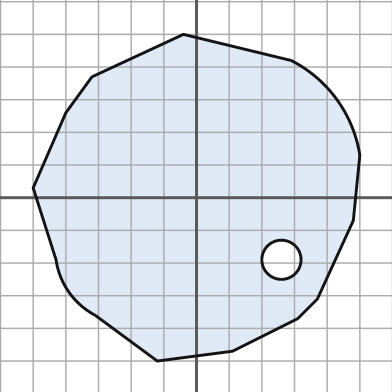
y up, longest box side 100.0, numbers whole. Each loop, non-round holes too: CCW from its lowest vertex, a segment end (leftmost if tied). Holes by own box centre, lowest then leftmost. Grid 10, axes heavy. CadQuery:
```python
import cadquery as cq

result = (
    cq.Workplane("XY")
    .moveTo(-12.0, -50.0)
    .lineTo(11.0, -47.0)
    .lineTo(31.0, -37.0)
    .lineTo(37.0, -31.0)
    .lineTo(48.0, -7.0)
    .lineTo(50.0, 13.0)
    .threePointArc((43.0, 30.0), (29.0, 42.0))
    .lineTo(-4.0, 50.0)
    .lineTo(-32.0, 37.0)
    .lineTo(-40.0, 26.0)
    .lineTo(-50.0, 3.0)
    .lineTo(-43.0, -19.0)
    .threePointArc((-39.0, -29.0), (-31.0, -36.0))
    .close()
    .moveTo(26.0, -19.0)
    .circle(6.0)
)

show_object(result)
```